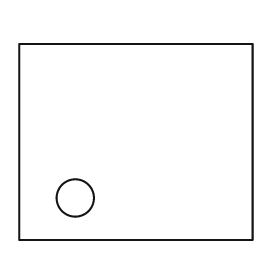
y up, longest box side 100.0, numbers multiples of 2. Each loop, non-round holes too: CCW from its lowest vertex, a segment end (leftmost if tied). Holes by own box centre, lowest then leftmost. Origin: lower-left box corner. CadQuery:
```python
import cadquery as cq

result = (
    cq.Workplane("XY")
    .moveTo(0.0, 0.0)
    .lineTo(100.0, 0.0)
    .lineTo(100.0, 84.0)
    .lineTo(0.0, 84.0)
    .close()
    .moveTo(24.0, 18.0)
    .circle(8.0)
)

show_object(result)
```